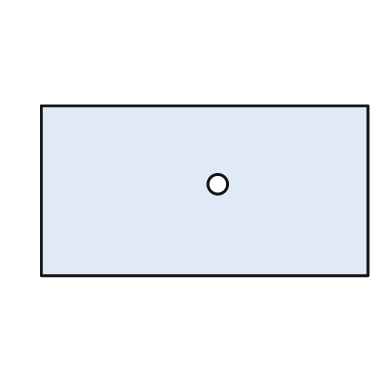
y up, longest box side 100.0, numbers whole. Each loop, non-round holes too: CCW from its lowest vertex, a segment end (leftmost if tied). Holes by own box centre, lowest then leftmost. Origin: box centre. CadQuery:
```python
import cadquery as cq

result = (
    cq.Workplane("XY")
    .moveTo(-50.0, -26.0)
    .lineTo(50.0, -26.0)
    .lineTo(50.0, 26.0)
    .lineTo(-50.0, 26.0)
    .close()
    .moveTo(4.0, 2.0)
    .circle(3.0)
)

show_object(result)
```